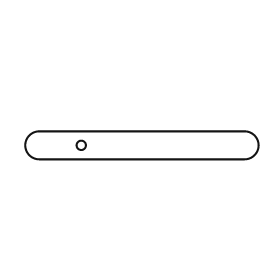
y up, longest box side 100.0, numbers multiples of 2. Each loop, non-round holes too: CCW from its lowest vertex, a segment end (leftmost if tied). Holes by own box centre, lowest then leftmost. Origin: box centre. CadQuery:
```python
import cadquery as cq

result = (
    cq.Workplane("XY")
    .moveTo(-44.0, -6.0)
    .lineTo(44.0, -6.0)
    .threePointArc((50.0, 0.0), (44.0, 6.0))
    .lineTo(-44.0, 6.0)
    .threePointArc((-50.0, 0.0), (-44.0, -6.0))
    .close()
    .moveTo(-26.0, 0.0)
    .circle(2.0)
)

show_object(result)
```